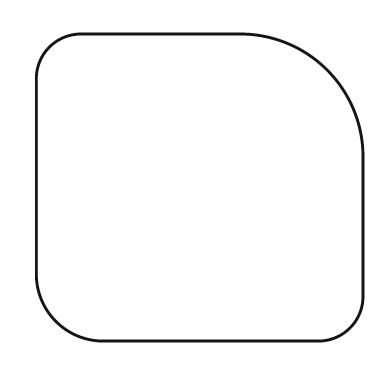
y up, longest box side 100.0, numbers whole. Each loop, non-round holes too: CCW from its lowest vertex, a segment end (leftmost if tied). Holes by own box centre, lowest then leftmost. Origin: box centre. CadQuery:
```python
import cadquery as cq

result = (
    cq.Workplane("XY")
    .moveTo(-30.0, -47.0)
    .lineTo(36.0, -47.0)
    .threePointArc((46.0, -43.0), (50.0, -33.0))
    .lineTo(50.0, 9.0)
    .threePointArc((39.0, 36.0), (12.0, 47.0))
    .lineTo(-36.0, 47.0)
    .threePointArc((-46.0, 43.0), (-50.0, 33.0))
    .lineTo(-50.0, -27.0)
    .threePointArc((-44.0, -41.0), (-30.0, -47.0))
    .close()
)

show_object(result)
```